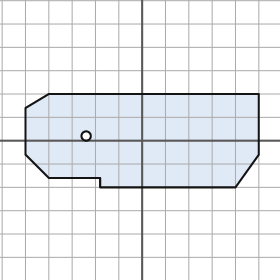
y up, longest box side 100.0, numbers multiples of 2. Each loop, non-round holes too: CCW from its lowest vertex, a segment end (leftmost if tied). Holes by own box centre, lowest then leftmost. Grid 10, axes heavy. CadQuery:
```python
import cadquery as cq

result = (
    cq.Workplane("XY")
    .moveTo(-18.0, -20.0)
    .lineTo(40.0, -20.0)
    .lineTo(50.0, -6.0)
    .lineTo(50.0, 20.0)
    .lineTo(-40.0, 20.0)
    .lineTo(-50.0, 14.0)
    .lineTo(-50.0, -6.0)
    .lineTo(-40.0, -16.0)
    .lineTo(-18.0, -16.0)
    .close()
    .moveTo(-24.0, 2.0)
    .circle(2.0)
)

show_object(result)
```